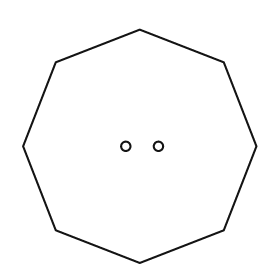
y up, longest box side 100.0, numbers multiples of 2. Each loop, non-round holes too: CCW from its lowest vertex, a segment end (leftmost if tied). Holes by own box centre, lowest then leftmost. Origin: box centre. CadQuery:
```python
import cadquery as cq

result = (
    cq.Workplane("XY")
    .moveTo(0.0, -50.0)
    .lineTo(36.0, -36.0)
    .lineTo(50.0, 0.0)
    .lineTo(36.0, 36.0)
    .lineTo(0.0, 50.0)
    .lineTo(-36.0, 36.0)
    .lineTo(-50.0, 0.0)
    .lineTo(-36.0, -36.0)
    .close()
    .moveTo(-6.0, 0.0)
    .circle(2.0)
    .moveTo(8.0, 0.0)
    .circle(2.0)
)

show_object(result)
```